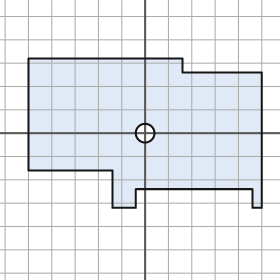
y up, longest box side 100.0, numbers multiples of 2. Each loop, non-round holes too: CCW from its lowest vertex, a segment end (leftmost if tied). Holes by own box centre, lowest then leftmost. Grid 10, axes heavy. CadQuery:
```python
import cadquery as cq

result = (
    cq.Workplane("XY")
    .moveTo(-14.0, -32.0)
    .lineTo(-4.0, -32.0)
    .lineTo(-4.0, -24.0)
    .lineTo(46.0, -24.0)
    .lineTo(46.0, -32.0)
    .lineTo(50.0, -32.0)
    .lineTo(50.0, 26.0)
    .lineTo(16.0, 26.0)
    .lineTo(16.0, 32.0)
    .lineTo(-50.0, 32.0)
    .lineTo(-50.0, -16.0)
    .lineTo(-14.0, -16.0)
    .close()
    .moveTo(0.0, 0.0)
    .circle(4.0)
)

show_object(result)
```